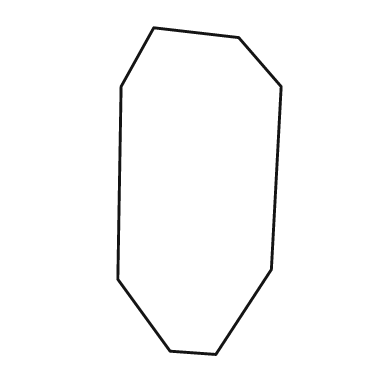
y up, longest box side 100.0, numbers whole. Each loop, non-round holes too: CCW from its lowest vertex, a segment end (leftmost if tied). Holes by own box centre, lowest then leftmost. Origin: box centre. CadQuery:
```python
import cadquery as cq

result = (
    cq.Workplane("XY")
    .moveTo(5.0, -50.0)
    .lineTo(22.0, -24.0)
    .lineTo(25.0, 32.0)
    .lineTo(12.0, 47.0)
    .lineTo(-14.0, 50.0)
    .lineTo(-24.0, 32.0)
    .lineTo(-25.0, -27.0)
    .lineTo(-9.0, -49.0)
    .close()
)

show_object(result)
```